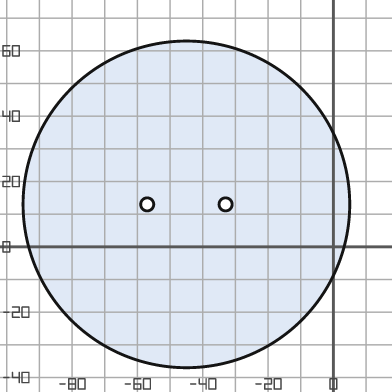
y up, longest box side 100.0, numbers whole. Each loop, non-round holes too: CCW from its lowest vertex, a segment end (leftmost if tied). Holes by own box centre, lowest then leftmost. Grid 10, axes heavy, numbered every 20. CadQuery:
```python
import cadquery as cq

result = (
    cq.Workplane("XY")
    .moveTo(-45.0, 13.0)
    .circle(50.0)
    .moveTo(-57.0, 13.0)
    .circle(2.0)
    .moveTo(-33.0, 13.0)
    .circle(2.0)
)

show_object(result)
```